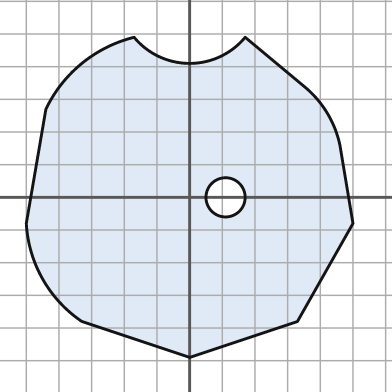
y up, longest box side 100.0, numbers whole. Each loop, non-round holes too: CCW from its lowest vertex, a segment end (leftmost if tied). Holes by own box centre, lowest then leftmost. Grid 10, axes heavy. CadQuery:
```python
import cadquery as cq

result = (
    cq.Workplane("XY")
    .moveTo(0.0, -49.0)
    .lineTo(33.0, -38.0)
    .lineTo(50.0, -8.0)
    .lineTo(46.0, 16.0)
    .threePointArc((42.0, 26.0), (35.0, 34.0))
    .lineTo(17.0, 49.0)
    .threePointArc((0.0, 41.0), (-17.0, 49.0))
    .threePointArc((-33.0, 41.0), (-44.0, 27.0))
    .lineTo(-50.0, -8.0)
    .threePointArc((-45.0, -25.0), (-33.0, -38.0))
    .close()
    .moveTo(11.0, 0.0)
    .circle(6.0)
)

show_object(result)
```